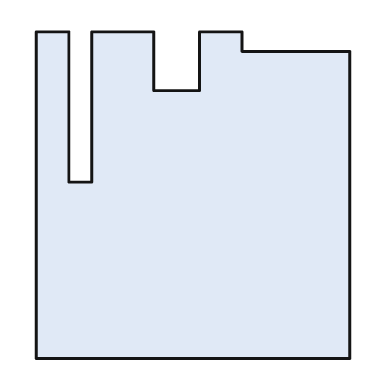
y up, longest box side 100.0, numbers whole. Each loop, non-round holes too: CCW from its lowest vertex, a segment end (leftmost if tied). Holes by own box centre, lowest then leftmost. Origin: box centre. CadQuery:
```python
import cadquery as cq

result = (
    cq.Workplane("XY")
    .moveTo(-48.0, -50.0)
    .lineTo(48.0, -50.0)
    .lineTo(48.0, 44.0)
    .lineTo(15.0, 44.0)
    .lineTo(15.0, 50.0)
    .lineTo(2.0, 50.0)
    .lineTo(2.0, 32.0)
    .lineTo(-12.0, 32.0)
    .lineTo(-12.0, 50.0)
    .lineTo(-31.0, 50.0)
    .lineTo(-31.0, 4.0)
    .lineTo(-38.0, 4.0)
    .lineTo(-38.0, 50.0)
    .lineTo(-48.0, 50.0)
    .close()
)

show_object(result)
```